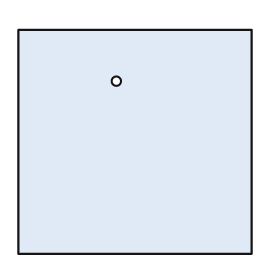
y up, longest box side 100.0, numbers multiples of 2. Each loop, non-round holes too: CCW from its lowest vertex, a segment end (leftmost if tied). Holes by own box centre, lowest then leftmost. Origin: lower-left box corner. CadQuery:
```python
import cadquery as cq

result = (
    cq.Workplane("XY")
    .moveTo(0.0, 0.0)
    .lineTo(100.0, 0.0)
    .lineTo(100.0, 96.0)
    .lineTo(0.0, 96.0)
    .close()
    .moveTo(42.0, 74.0)
    .circle(2.0)
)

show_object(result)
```